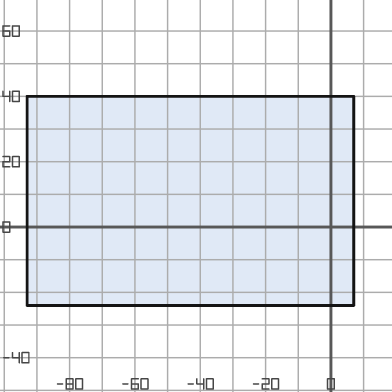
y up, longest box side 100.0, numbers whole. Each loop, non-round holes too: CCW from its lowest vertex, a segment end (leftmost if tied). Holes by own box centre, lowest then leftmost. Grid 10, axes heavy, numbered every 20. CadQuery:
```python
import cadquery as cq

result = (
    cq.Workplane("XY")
    .moveTo(-93.0, -24.0)
    .lineTo(7.0, -24.0)
    .lineTo(7.0, 40.0)
    .lineTo(-93.0, 40.0)
    .close()
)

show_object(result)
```